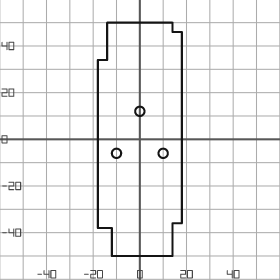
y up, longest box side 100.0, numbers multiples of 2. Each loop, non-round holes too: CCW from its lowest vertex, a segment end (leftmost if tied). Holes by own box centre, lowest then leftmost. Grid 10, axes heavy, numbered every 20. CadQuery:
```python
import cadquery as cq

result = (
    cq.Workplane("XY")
    .moveTo(-12.0, -50.0)
    .lineTo(14.0, -50.0)
    .lineTo(14.0, -36.0)
    .lineTo(18.0, -36.0)
    .lineTo(18.0, 46.0)
    .lineTo(14.0, 46.0)
    .lineTo(14.0, 50.0)
    .lineTo(-14.0, 50.0)
    .lineTo(-14.0, 34.0)
    .lineTo(-18.0, 34.0)
    .lineTo(-18.0, -38.0)
    .lineTo(-12.0, -38.0)
    .close()
    .moveTo(-10.0, -6.0)
    .circle(2.0)
    .moveTo(10.0, -6.0)
    .circle(2.0)
    .moveTo(0.0, 12.0)
    .circle(2.0)
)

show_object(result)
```